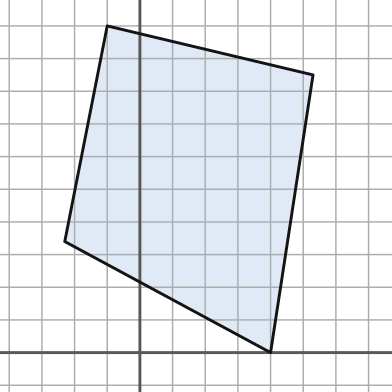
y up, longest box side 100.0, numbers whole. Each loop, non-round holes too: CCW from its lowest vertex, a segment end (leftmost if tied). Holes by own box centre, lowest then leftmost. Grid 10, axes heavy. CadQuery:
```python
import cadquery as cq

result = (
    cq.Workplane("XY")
    .moveTo(40.0, 0.0)
    .lineTo(53.0, 85.0)
    .lineTo(-10.0, 100.0)
    .lineTo(-23.0, 34.0)
    .close()
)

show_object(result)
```